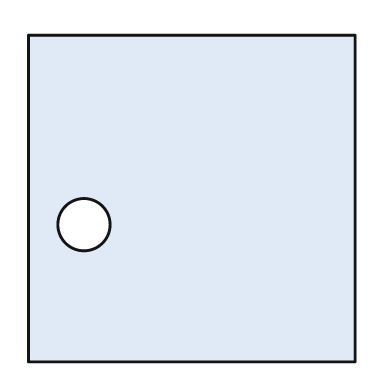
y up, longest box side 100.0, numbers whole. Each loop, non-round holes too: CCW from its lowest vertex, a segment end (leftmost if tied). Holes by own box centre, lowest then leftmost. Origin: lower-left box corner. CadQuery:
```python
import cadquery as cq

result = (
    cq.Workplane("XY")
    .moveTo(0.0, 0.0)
    .lineTo(100.0, 0.0)
    .lineTo(100.0, 100.0)
    .lineTo(0.0, 100.0)
    .close()
    .moveTo(17.0, 42.0)
    .circle(8.0)
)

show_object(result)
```